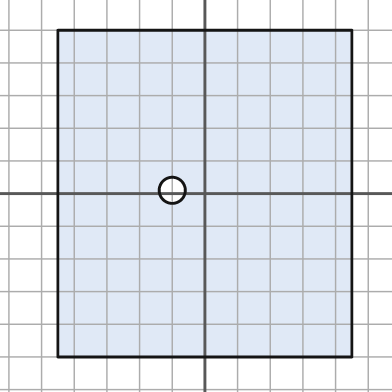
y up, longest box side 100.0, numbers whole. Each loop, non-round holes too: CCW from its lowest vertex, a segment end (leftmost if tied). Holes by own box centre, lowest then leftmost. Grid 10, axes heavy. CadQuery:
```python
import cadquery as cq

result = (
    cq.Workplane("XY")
    .moveTo(-45.0, -50.0)
    .lineTo(45.0, -50.0)
    .lineTo(45.0, 50.0)
    .lineTo(-45.0, 50.0)
    .close()
    .moveTo(-10.0, 1.0)
    .circle(4.0)
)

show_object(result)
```